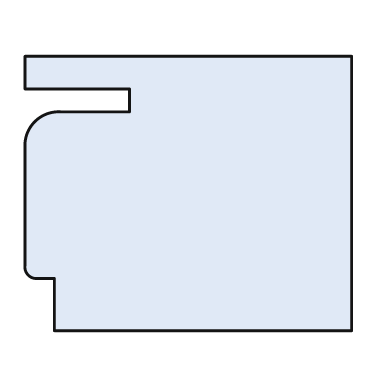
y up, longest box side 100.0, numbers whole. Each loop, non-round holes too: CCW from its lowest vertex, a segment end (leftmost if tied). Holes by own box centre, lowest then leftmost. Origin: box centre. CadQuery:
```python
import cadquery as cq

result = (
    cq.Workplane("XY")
    .moveTo(-41.0, -42.0)
    .lineTo(50.0, -42.0)
    .lineTo(50.0, 42.0)
    .lineTo(-50.0, 42.0)
    .lineTo(-50.0, 32.0)
    .lineTo(-18.0, 32.0)
    .lineTo(-18.0, 25.0)
    .lineTo(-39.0, 25.0)
    .threePointArc((-47.0, 22.0), (-50.0, 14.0))
    .lineTo(-50.0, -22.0)
    .threePointArc((-49.0, -25.0), (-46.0, -26.0))
    .lineTo(-41.0, -26.0)
    .close()
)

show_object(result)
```